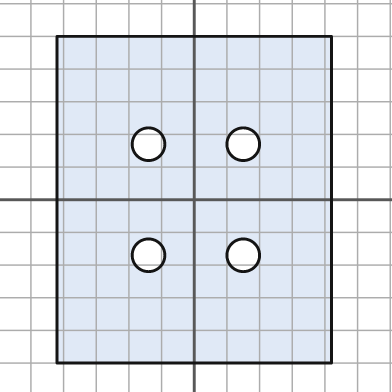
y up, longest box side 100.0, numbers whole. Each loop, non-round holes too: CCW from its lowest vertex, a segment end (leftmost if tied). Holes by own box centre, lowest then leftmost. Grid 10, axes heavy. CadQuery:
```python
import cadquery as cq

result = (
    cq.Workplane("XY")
    .moveTo(-42.0, -50.0)
    .lineTo(42.0, -50.0)
    .lineTo(42.0, 50.0)
    .lineTo(-42.0, 50.0)
    .close()
    .moveTo(-14.0, -17.0)
    .circle(5.0)
    .moveTo(15.0, -17.0)
    .circle(5.0)
    .moveTo(-14.0, 17.0)
    .circle(5.0)
    .moveTo(15.0, 17.0)
    .circle(5.0)
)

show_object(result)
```